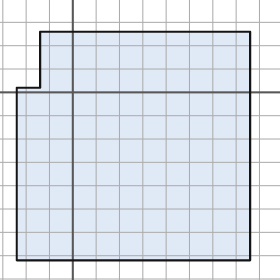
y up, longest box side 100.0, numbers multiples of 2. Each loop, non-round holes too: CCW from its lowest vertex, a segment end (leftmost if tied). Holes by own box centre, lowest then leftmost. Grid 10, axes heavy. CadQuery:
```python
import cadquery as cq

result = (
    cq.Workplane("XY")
    .moveTo(-24.0, -72.0)
    .lineTo(76.0, -72.0)
    .lineTo(76.0, 26.0)
    .lineTo(-14.0, 26.0)
    .lineTo(-14.0, 2.0)
    .lineTo(-24.0, 2.0)
    .close()
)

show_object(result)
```